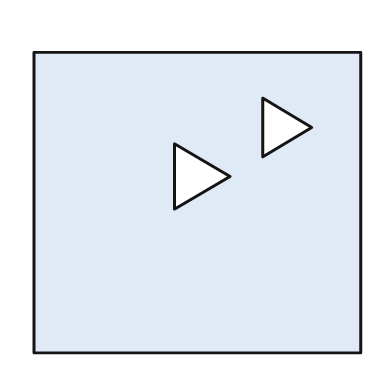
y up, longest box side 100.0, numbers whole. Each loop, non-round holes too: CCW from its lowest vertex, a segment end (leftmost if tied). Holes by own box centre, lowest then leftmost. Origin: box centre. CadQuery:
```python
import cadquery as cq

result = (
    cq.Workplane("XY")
    .moveTo(-50.0, -46.0)
    .lineTo(50.0, -46.0)
    .lineTo(50.0, 46.0)
    .lineTo(-50.0, 46.0)
    .close()
    .moveTo(-7.0, -2.0)
    .lineTo(10.0, 8.0)
    .lineTo(-7.0, 18.0)
    .close()
    .moveTo(20.0, 14.0)
    .lineTo(35.0, 23.0)
    .lineTo(20.0, 32.0)
    .close()
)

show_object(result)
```